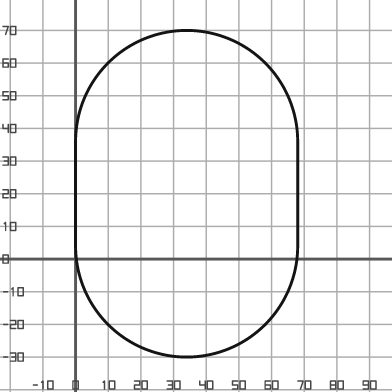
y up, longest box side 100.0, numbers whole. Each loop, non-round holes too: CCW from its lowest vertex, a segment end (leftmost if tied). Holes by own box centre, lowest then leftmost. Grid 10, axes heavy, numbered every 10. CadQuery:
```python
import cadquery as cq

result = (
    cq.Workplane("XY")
    .moveTo(0.0, 4.0)
    .threePointArc((34.0, -30.0), (68.0, 4.0))
    .lineTo(68.0, 36.0)
    .threePointArc((34.0, 70.0), (0.0, 36.0))
    .close()
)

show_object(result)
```